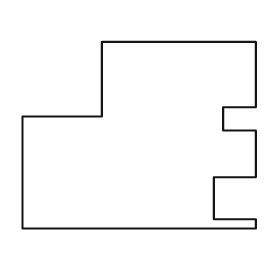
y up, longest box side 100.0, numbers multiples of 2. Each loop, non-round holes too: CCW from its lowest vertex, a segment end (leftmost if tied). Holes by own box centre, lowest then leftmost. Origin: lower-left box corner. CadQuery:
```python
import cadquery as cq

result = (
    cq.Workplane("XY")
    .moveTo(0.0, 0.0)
    .lineTo(100.0, 0.0)
    .lineTo(100.0, 4.0)
    .lineTo(82.0, 4.0)
    .lineTo(82.0, 22.0)
    .lineTo(100.0, 22.0)
    .lineTo(100.0, 42.0)
    .lineTo(86.0, 42.0)
    .lineTo(86.0, 52.0)
    .lineTo(100.0, 52.0)
    .lineTo(100.0, 80.0)
    .lineTo(34.0, 80.0)
    .lineTo(34.0, 48.0)
    .lineTo(0.0, 48.0)
    .close()
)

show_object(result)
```